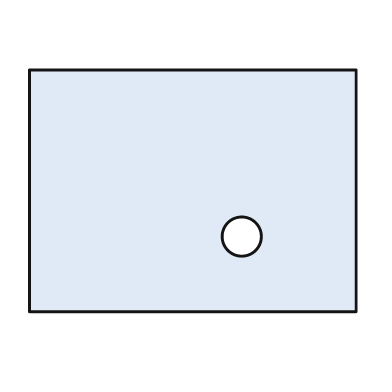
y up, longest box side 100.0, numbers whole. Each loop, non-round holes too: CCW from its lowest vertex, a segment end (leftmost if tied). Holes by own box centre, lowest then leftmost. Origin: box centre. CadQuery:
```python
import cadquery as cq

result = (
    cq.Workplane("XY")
    .moveTo(-50.0, -37.0)
    .lineTo(50.0, -37.0)
    .lineTo(50.0, 37.0)
    .lineTo(-50.0, 37.0)
    .close()
    .moveTo(15.0, -14.0)
    .circle(6.0)
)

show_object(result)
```